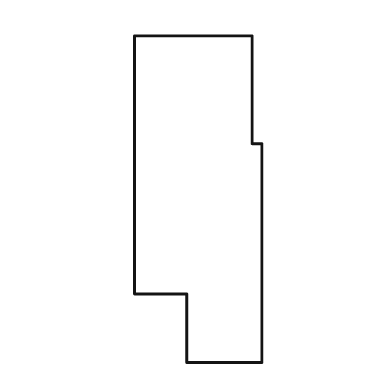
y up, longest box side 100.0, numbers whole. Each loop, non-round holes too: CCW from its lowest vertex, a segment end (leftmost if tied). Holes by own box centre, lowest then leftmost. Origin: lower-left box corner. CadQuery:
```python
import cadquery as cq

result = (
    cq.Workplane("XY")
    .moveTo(16.0, 0.0)
    .lineTo(39.0, 0.0)
    .lineTo(39.0, 67.0)
    .lineTo(36.0, 67.0)
    .lineTo(36.0, 100.0)
    .lineTo(0.0, 100.0)
    .lineTo(0.0, 21.0)
    .lineTo(16.0, 21.0)
    .close()
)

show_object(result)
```